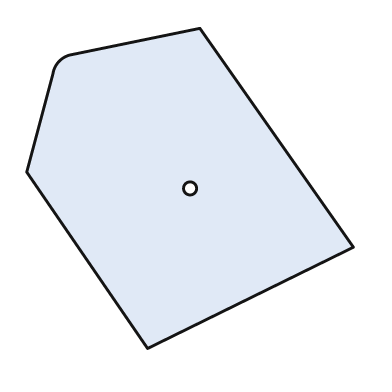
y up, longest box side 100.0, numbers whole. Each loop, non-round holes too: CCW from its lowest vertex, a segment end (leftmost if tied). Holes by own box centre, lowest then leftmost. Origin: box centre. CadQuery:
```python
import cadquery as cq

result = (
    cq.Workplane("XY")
    .moveTo(-13.0, -49.0)
    .lineTo(50.0, -18.0)
    .lineTo(3.0, 49.0)
    .lineTo(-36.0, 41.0)
    .threePointArc((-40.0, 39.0), (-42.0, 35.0))
    .lineTo(-50.0, 5.0)
    .close()
    .moveTo(0.0, 0.0)
    .circle(2.0)
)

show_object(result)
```